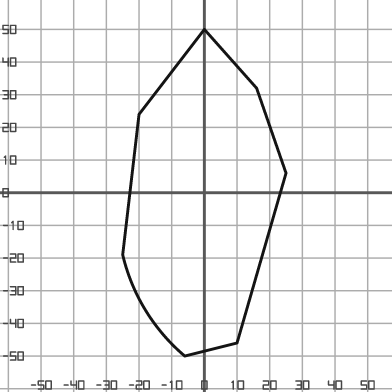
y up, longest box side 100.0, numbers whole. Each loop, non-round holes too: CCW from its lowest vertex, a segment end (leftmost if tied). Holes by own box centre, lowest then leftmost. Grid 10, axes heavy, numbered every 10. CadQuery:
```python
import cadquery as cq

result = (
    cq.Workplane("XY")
    .moveTo(-6.0, -50.0)
    .lineTo(10.0, -46.0)
    .lineTo(25.0, 6.0)
    .lineTo(16.0, 32.0)
    .lineTo(0.0, 50.0)
    .lineTo(-20.0, 24.0)
    .lineTo(-25.0, -19.0)
    .threePointArc((-18.0, -36.0), (-6.0, -50.0))
    .close()
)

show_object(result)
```